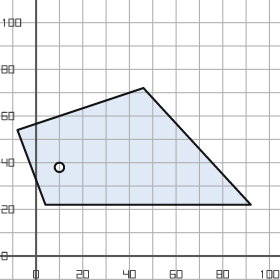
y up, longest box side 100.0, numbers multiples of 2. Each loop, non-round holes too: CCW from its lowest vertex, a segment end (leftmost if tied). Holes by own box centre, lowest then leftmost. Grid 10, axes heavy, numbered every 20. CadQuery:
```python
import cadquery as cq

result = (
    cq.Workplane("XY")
    .moveTo(4.0, 22.0)
    .lineTo(92.0, 22.0)
    .lineTo(46.0, 72.0)
    .lineTo(-8.0, 54.0)
    .close()
    .moveTo(10.0, 38.0)
    .circle(2.0)
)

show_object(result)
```